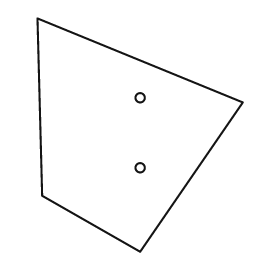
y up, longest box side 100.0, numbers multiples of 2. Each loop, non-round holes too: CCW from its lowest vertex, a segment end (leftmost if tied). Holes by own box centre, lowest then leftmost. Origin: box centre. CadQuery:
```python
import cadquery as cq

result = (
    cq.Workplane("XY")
    .moveTo(0.0, -50.0)
    .lineTo(44.0, 14.0)
    .lineTo(-44.0, 50.0)
    .lineTo(-42.0, -26.0)
    .close()
    .moveTo(0.0, -14.0)
    .circle(2.0)
    .moveTo(0.0, 16.0)
    .circle(2.0)
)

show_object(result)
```